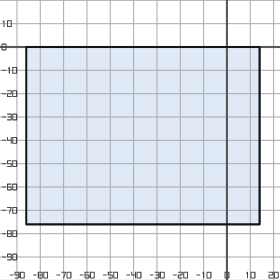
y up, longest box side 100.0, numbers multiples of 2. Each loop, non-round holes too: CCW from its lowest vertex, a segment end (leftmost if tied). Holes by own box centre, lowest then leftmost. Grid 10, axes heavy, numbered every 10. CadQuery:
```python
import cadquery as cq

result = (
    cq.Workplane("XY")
    .moveTo(-86.0, -76.0)
    .lineTo(14.0, -76.0)
    .lineTo(14.0, 0.0)
    .lineTo(-86.0, 0.0)
    .close()
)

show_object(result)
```